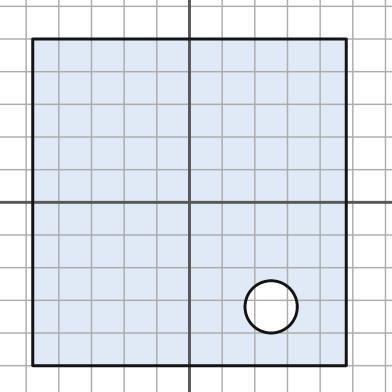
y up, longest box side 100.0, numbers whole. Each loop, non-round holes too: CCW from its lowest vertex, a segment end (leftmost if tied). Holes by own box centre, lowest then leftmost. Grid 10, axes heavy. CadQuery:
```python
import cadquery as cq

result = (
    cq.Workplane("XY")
    .moveTo(-48.0, -50.0)
    .lineTo(48.0, -50.0)
    .lineTo(48.0, 50.0)
    .lineTo(-48.0, 50.0)
    .close()
    .moveTo(25.0, -32.0)
    .circle(8.0)
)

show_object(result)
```